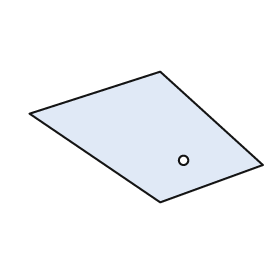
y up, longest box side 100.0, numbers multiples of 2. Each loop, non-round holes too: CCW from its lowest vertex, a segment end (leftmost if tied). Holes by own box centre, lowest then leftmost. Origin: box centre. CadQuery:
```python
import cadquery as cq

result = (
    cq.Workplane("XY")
    .moveTo(6.0, -28.0)
    .lineTo(50.0, -12.0)
    .lineTo(6.0, 28.0)
    .lineTo(-50.0, 10.0)
    .close()
    .moveTo(16.0, -10.0)
    .circle(2.0)
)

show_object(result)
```